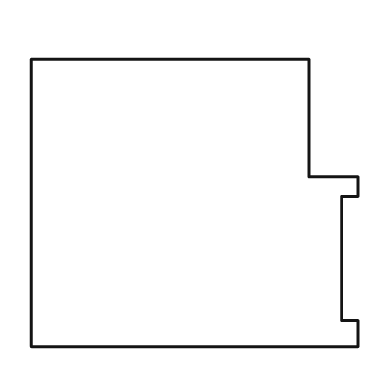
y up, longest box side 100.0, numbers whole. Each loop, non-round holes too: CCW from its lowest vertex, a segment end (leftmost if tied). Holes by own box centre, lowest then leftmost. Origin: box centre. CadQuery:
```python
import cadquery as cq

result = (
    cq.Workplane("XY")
    .moveTo(-50.0, -44.0)
    .lineTo(50.0, -44.0)
    .lineTo(50.0, -36.0)
    .lineTo(45.0, -36.0)
    .lineTo(45.0, 2.0)
    .lineTo(50.0, 2.0)
    .lineTo(50.0, 8.0)
    .lineTo(35.0, 8.0)
    .lineTo(35.0, 44.0)
    .lineTo(-50.0, 44.0)
    .close()
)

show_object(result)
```